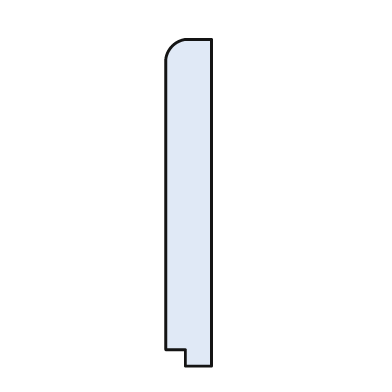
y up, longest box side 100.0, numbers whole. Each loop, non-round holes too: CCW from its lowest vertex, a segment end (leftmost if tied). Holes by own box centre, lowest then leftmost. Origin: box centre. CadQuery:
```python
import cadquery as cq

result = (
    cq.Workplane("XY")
    .moveTo(-1.0, -50.0)
    .lineTo(7.0, -50.0)
    .lineTo(7.0, 50.0)
    .lineTo(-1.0, 50.0)
    .threePointArc((-5.0, 48.0), (-7.0, 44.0))
    .lineTo(-7.0, -45.0)
    .lineTo(-1.0, -45.0)
    .close()
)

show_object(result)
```